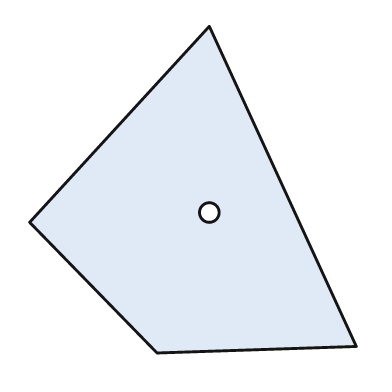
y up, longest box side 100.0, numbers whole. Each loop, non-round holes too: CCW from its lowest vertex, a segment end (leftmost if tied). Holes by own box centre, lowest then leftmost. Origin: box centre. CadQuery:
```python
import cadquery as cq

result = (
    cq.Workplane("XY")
    .moveTo(-11.0, -50.0)
    .lineTo(50.0, -48.0)
    .lineTo(5.0, 50.0)
    .lineTo(-50.0, -10.0)
    .close()
    .moveTo(5.0, -7.0)
    .circle(3.0)
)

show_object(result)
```